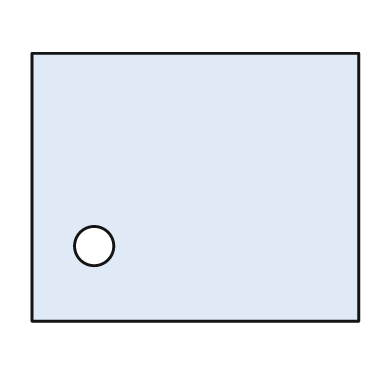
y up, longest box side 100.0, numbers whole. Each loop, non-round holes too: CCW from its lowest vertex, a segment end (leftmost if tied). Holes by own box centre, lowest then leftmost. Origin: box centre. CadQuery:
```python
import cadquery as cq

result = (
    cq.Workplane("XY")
    .moveTo(-50.0, -41.0)
    .lineTo(50.0, -41.0)
    .lineTo(50.0, 41.0)
    .lineTo(-50.0, 41.0)
    .close()
    .moveTo(-31.0, -18.0)
    .circle(6.0)
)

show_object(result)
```